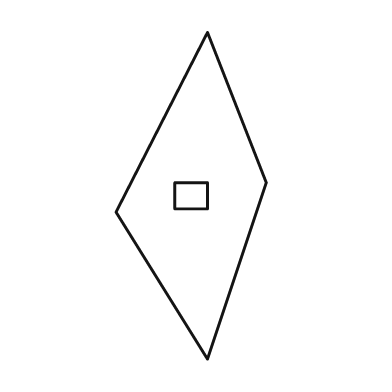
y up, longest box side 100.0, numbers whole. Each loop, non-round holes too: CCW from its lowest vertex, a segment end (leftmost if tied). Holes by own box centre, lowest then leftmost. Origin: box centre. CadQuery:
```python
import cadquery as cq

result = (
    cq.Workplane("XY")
    .moveTo(5.0, -50.0)
    .lineTo(23.0, 4.0)
    .lineTo(5.0, 50.0)
    .lineTo(-23.0, -5.0)
    .close()
    .moveTo(-5.0, -4.0)
    .lineTo(5.0, -4.0)
    .lineTo(5.0, 4.0)
    .lineTo(-5.0, 4.0)
    .close()
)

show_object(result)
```